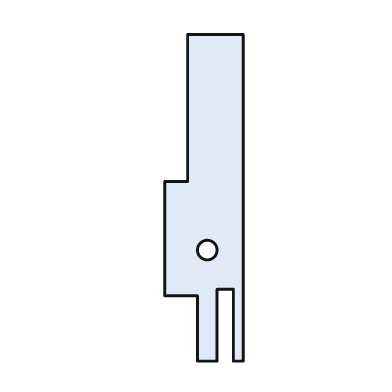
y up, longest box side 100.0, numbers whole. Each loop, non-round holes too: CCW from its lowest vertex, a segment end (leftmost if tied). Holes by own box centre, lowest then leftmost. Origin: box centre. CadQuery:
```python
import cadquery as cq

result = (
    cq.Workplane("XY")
    .moveTo(-2.0, -50.0)
    .lineTo(4.0, -50.0)
    .lineTo(4.0, -28.0)
    .lineTo(9.0, -28.0)
    .lineTo(9.0, -50.0)
    .lineTo(12.0, -50.0)
    .lineTo(12.0, 50.0)
    .lineTo(-5.0, 50.0)
    .lineTo(-5.0, 5.0)
    .lineTo(-12.0, 5.0)
    .lineTo(-12.0, -30.0)
    .lineTo(-2.0, -30.0)
    .close()
    .moveTo(1.0, -16.0)
    .circle(3.0)
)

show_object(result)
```